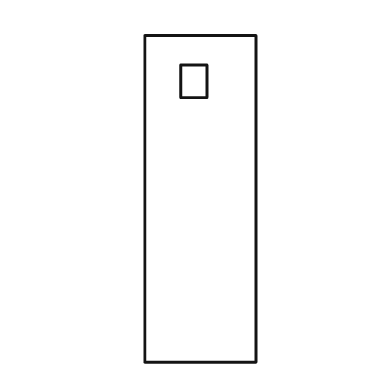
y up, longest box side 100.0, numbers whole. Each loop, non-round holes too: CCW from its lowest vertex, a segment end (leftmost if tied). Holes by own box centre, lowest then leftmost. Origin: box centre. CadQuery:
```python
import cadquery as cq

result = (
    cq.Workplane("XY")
    .moveTo(-17.0, -50.0)
    .lineTo(17.0, -50.0)
    .lineTo(17.0, 50.0)
    .lineTo(-17.0, 50.0)
    .close()
    .moveTo(-6.0, 31.0)
    .lineTo(2.0, 31.0)
    .lineTo(2.0, 41.0)
    .lineTo(-6.0, 41.0)
    .close()
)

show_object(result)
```